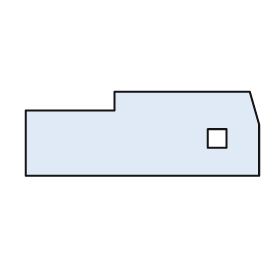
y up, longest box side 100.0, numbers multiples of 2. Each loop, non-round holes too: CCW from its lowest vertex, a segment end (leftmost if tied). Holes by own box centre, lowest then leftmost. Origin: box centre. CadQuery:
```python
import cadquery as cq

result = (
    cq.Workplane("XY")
    .moveTo(-50.0, -18.0)
    .lineTo(50.0, -18.0)
    .lineTo(50.0, 4.0)
    .lineTo(46.0, 18.0)
    .lineTo(-12.0, 18.0)
    .lineTo(-12.0, 10.0)
    .lineTo(-50.0, 10.0)
    .close()
    .moveTo(28.0, -6.0)
    .lineTo(36.0, -6.0)
    .lineTo(36.0, 2.0)
    .lineTo(28.0, 2.0)
    .close()
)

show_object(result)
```